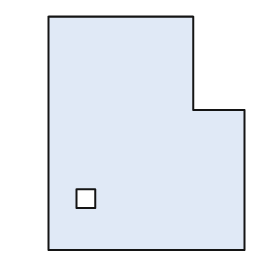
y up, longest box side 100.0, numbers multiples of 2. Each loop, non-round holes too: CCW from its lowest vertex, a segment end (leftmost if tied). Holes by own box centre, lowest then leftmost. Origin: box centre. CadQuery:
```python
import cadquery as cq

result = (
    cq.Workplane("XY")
    .moveTo(-42.0, -50.0)
    .lineTo(42.0, -50.0)
    .lineTo(42.0, 10.0)
    .lineTo(20.0, 10.0)
    .lineTo(20.0, 50.0)
    .lineTo(-42.0, 50.0)
    .close()
    .moveTo(-30.0, -32.0)
    .lineTo(-22.0, -32.0)
    .lineTo(-22.0, -24.0)
    .lineTo(-30.0, -24.0)
    .close()
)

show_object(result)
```